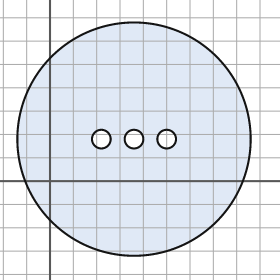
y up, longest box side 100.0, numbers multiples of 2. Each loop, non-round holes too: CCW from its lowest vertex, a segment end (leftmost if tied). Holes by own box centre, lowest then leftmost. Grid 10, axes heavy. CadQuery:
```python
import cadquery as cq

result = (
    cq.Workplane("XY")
    .moveTo(36.0, 18.0)
    .circle(50.0)
    .moveTo(22.0, 18.0)
    .circle(4.0)
    .moveTo(36.0, 18.0)
    .circle(4.0)
    .moveTo(50.0, 18.0)
    .circle(4.0)
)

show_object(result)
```